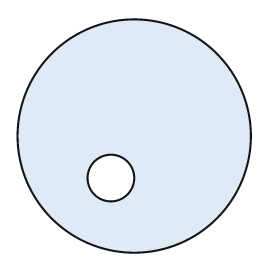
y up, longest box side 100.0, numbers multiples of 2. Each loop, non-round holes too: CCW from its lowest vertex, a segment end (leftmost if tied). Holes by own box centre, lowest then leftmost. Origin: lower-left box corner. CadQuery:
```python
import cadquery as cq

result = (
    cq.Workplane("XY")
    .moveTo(50.0, 50.0)
    .circle(50.0)
    .moveTo(40.0, 32.0)
    .circle(10.0)
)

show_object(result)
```